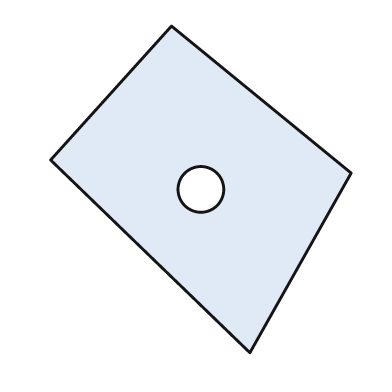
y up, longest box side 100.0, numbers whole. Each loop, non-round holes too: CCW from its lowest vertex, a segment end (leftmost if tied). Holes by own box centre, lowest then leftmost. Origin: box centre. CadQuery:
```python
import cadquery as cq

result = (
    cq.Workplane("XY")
    .moveTo(15.0, -50.0)
    .lineTo(46.0, 5.0)
    .lineTo(-9.0, 50.0)
    .lineTo(-46.0, 9.0)
    .close()
    .moveTo(0.0, 0.0)
    .circle(7.0)
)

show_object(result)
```